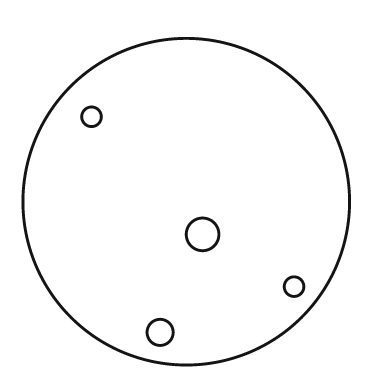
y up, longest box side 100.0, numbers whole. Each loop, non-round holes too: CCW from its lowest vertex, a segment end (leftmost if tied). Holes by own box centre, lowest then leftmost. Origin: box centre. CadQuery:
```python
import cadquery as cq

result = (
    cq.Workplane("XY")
    .moveTo(0.0, 0.0)
    .circle(50.0)
    .moveTo(-8.0, -40.0)
    .circle(4.0)
    .moveTo(33.0, -26.0)
    .circle(3.0)
    .moveTo(5.0, -10.0)
    .circle(5.0)
    .moveTo(-29.0, 26.0)
    .circle(3.0)
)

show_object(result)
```